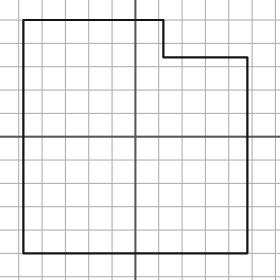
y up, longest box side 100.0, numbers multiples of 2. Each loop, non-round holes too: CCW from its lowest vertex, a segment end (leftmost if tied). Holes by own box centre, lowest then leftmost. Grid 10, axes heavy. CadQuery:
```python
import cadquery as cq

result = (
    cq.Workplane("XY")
    .moveTo(-48.0, -50.0)
    .lineTo(48.0, -50.0)
    .lineTo(48.0, 34.0)
    .lineTo(12.0, 34.0)
    .lineTo(12.0, 50.0)
    .lineTo(-48.0, 50.0)
    .close()
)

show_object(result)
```